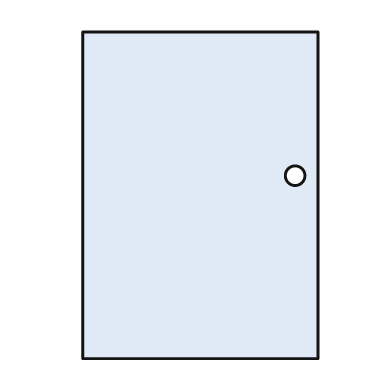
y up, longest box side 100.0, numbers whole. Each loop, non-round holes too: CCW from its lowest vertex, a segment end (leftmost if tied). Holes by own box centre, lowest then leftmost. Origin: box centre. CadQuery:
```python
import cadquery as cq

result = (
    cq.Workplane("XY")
    .moveTo(-36.0, -50.0)
    .lineTo(36.0, -50.0)
    .lineTo(36.0, 50.0)
    .lineTo(-36.0, 50.0)
    .close()
    .moveTo(29.0, 6.0)
    .circle(3.0)
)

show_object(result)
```